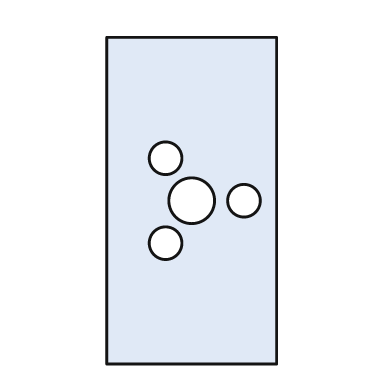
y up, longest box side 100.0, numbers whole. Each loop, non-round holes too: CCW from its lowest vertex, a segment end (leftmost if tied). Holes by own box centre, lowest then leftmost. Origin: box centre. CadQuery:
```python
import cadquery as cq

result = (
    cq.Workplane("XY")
    .moveTo(-26.0, -50.0)
    .lineTo(26.0, -50.0)
    .lineTo(26.0, 50.0)
    .lineTo(-26.0, 50.0)
    .close()
    .moveTo(-8.0, -13.0)
    .circle(5.0)
    .moveTo(0.0, 0.0)
    .circle(7.0)
    .moveTo(16.0, 0.0)
    .circle(5.0)
    .moveTo(-8.0, 13.0)
    .circle(5.0)
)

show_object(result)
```